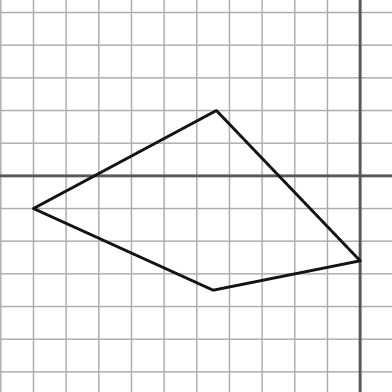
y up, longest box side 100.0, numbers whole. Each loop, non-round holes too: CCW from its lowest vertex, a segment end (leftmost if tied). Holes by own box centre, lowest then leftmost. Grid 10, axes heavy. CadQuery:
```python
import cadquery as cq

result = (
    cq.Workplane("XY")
    .moveTo(-45.0, -35.0)
    .lineTo(0.0, -26.0)
    .lineTo(-44.0, 20.0)
    .lineTo(-100.0, -10.0)
    .close()
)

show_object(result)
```